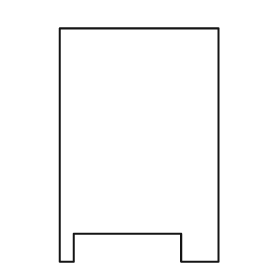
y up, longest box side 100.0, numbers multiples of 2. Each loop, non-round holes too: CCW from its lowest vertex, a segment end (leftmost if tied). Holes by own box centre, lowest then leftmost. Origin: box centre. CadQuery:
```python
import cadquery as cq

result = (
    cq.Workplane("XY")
    .moveTo(-34.0, -50.0)
    .lineTo(-28.0, -50.0)
    .lineTo(-28.0, -38.0)
    .lineTo(18.0, -38.0)
    .lineTo(18.0, -50.0)
    .lineTo(34.0, -50.0)
    .lineTo(34.0, 50.0)
    .lineTo(-34.0, 50.0)
    .close()
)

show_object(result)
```